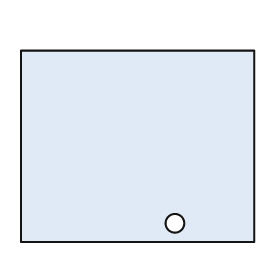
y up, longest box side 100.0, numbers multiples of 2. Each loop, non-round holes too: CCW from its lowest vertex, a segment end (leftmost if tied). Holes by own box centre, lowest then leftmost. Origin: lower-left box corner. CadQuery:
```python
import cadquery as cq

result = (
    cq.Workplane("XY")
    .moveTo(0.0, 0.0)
    .lineTo(100.0, 0.0)
    .lineTo(100.0, 82.0)
    .lineTo(0.0, 82.0)
    .close()
    .moveTo(66.0, 8.0)
    .circle(4.0)
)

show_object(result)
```